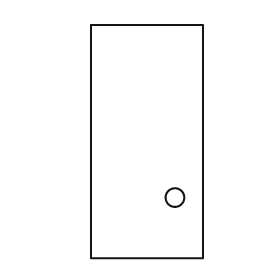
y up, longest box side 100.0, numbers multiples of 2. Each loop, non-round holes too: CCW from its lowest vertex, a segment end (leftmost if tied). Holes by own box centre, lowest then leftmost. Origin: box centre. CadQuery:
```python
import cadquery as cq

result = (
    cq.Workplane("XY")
    .moveTo(-24.0, -50.0)
    .lineTo(24.0, -50.0)
    .lineTo(24.0, 50.0)
    .lineTo(-24.0, 50.0)
    .close()
    .moveTo(12.0, -24.0)
    .circle(4.0)
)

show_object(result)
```